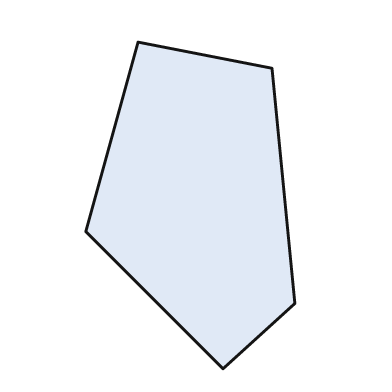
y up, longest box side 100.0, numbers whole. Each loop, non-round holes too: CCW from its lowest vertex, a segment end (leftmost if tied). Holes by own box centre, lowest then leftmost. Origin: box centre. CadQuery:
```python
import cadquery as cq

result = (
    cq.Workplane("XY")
    .moveTo(10.0, -50.0)
    .lineTo(32.0, -30.0)
    .lineTo(25.0, 42.0)
    .lineTo(-16.0, 50.0)
    .lineTo(-32.0, -8.0)
    .close()
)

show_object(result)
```